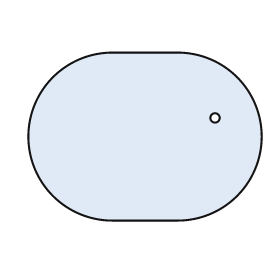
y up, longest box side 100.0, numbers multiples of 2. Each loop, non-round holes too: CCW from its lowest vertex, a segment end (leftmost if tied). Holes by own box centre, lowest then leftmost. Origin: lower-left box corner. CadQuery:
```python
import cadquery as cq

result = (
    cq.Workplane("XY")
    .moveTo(36.0, 0.0)
    .lineTo(64.0, 0.0)
    .threePointArc((100.0, 36.0), (64.0, 72.0))
    .lineTo(36.0, 72.0)
    .threePointArc((0.0, 36.0), (36.0, 0.0))
    .close()
    .moveTo(80.0, 44.0)
    .circle(2.0)
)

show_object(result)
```